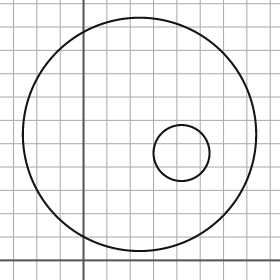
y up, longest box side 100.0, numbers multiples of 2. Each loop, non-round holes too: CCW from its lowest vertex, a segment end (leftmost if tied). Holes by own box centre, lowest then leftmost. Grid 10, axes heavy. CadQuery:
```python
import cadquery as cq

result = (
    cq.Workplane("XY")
    .moveTo(24.0, 54.0)
    .circle(50.0)
    .moveTo(42.0, 46.0)
    .circle(12.0)
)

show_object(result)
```